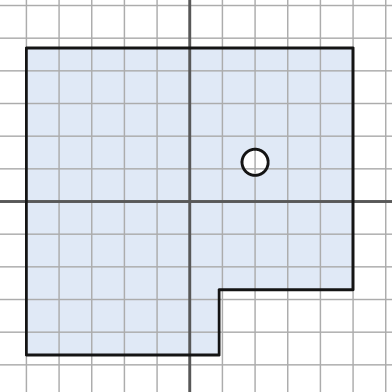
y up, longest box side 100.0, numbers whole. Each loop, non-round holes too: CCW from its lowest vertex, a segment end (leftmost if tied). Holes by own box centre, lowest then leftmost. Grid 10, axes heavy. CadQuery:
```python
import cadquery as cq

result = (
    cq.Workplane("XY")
    .moveTo(-50.0, -47.0)
    .lineTo(9.0, -47.0)
    .lineTo(9.0, -27.0)
    .lineTo(50.0, -27.0)
    .lineTo(50.0, 47.0)
    .lineTo(-50.0, 47.0)
    .close()
    .moveTo(20.0, 12.0)
    .circle(4.0)
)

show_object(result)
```